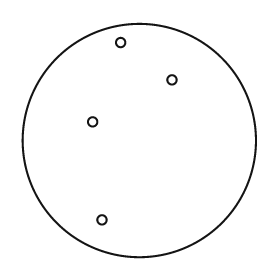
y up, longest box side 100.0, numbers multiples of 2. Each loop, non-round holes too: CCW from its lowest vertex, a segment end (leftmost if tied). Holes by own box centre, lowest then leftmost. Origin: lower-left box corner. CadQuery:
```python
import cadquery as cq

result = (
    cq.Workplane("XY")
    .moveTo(50.0, 50.0)
    .circle(50.0)
    .moveTo(34.0, 16.0)
    .circle(2.0)
    .moveTo(30.0, 58.0)
    .circle(2.0)
    .moveTo(64.0, 76.0)
    .circle(2.0)
    .moveTo(42.0, 92.0)
    .circle(2.0)
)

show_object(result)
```